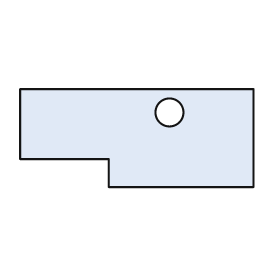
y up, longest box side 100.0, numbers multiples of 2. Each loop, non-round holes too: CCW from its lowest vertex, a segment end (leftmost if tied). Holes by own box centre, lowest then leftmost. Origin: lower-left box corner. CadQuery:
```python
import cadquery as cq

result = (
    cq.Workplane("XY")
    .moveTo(38.0, 0.0)
    .lineTo(100.0, 0.0)
    .lineTo(100.0, 42.0)
    .lineTo(0.0, 42.0)
    .lineTo(0.0, 12.0)
    .lineTo(38.0, 12.0)
    .close()
    .moveTo(64.0, 32.0)
    .circle(6.0)
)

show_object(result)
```